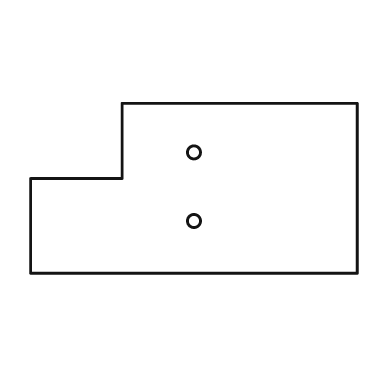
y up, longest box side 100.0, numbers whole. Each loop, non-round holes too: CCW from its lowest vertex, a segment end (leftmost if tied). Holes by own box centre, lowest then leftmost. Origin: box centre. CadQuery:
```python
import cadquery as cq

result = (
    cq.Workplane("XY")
    .moveTo(-50.0, -26.0)
    .lineTo(50.0, -26.0)
    .lineTo(50.0, 26.0)
    .lineTo(-22.0, 26.0)
    .lineTo(-22.0, 3.0)
    .lineTo(-50.0, 3.0)
    .close()
    .moveTo(0.0, -10.0)
    .circle(2.0)
    .moveTo(0.0, 11.0)
    .circle(2.0)
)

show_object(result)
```